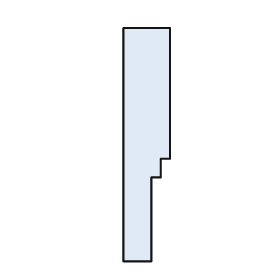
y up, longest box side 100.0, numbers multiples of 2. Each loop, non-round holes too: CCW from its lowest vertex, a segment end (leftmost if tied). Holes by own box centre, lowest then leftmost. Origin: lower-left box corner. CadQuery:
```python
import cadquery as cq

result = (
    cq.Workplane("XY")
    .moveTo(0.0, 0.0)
    .lineTo(12.0, 0.0)
    .lineTo(12.0, 36.0)
    .lineTo(16.0, 36.0)
    .lineTo(16.0, 44.0)
    .lineTo(20.0, 44.0)
    .lineTo(20.0, 100.0)
    .lineTo(0.0, 100.0)
    .close()
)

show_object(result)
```